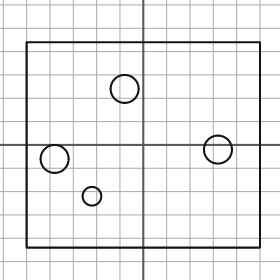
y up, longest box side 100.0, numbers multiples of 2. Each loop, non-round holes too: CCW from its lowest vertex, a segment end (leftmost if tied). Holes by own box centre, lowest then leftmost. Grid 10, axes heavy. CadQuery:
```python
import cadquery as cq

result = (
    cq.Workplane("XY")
    .moveTo(-50.0, -44.0)
    .lineTo(50.0, -44.0)
    .lineTo(50.0, 44.0)
    .lineTo(-50.0, 44.0)
    .close()
    .moveTo(-22.0, -22.0)
    .circle(4.0)
    .moveTo(-38.0, -6.0)
    .circle(6.0)
    .moveTo(32.0, -2.0)
    .circle(6.0)
    .moveTo(-8.0, 24.0)
    .circle(6.0)
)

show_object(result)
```